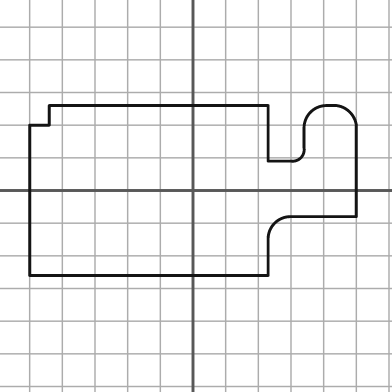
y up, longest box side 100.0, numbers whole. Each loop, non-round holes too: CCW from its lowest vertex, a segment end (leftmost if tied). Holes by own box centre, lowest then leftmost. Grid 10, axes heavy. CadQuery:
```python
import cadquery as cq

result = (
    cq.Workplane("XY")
    .moveTo(-50.0, -26.0)
    .lineTo(23.0, -26.0)
    .lineTo(23.0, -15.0)
    .threePointArc((25.0, -10.0), (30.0, -8.0))
    .lineTo(50.0, -8.0)
    .lineTo(50.0, 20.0)
    .threePointArc((48.0, 24.0), (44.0, 26.0))
    .lineTo(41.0, 26.0)
    .threePointArc((36.0, 24.0), (34.0, 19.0))
    .lineTo(34.0, 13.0)
    .threePointArc((33.0, 10.0), (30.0, 9.0))
    .lineTo(23.0, 9.0)
    .lineTo(23.0, 26.0)
    .lineTo(-44.0, 26.0)
    .lineTo(-44.0, 20.0)
    .lineTo(-50.0, 20.0)
    .close()
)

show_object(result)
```